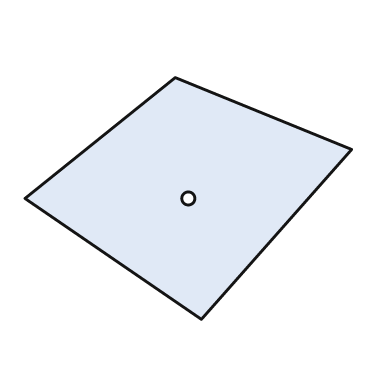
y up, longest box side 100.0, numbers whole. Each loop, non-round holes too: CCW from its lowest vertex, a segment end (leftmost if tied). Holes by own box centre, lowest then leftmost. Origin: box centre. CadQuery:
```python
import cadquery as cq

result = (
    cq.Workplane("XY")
    .moveTo(4.0, -37.0)
    .lineTo(50.0, 15.0)
    .lineTo(-4.0, 37.0)
    .lineTo(-50.0, 0.0)
    .close()
    .moveTo(0.0, 0.0)
    .circle(2.0)
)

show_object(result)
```